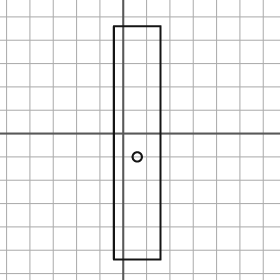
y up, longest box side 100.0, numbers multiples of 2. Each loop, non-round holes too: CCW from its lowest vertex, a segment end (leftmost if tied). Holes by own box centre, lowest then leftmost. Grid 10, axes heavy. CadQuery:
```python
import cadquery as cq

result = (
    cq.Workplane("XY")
    .moveTo(-4.0, -54.0)
    .lineTo(16.0, -54.0)
    .lineTo(16.0, 46.0)
    .lineTo(-4.0, 46.0)
    .close()
    .moveTo(6.0, -10.0)
    .circle(2.0)
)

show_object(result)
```